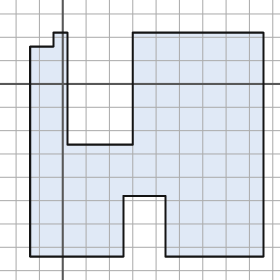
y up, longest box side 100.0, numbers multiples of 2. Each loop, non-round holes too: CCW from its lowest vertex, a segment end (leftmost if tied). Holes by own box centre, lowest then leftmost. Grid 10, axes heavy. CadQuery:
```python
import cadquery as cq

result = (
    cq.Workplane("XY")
    .moveTo(-14.0, -74.0)
    .lineTo(26.0, -74.0)
    .lineTo(26.0, -48.0)
    .lineTo(44.0, -48.0)
    .lineTo(44.0, -74.0)
    .lineTo(86.0, -74.0)
    .lineTo(86.0, 22.0)
    .lineTo(30.0, 22.0)
    .lineTo(30.0, -26.0)
    .lineTo(2.0, -26.0)
    .lineTo(2.0, 22.0)
    .lineTo(-4.0, 22.0)
    .lineTo(-4.0, 16.0)
    .lineTo(-14.0, 16.0)
    .close()
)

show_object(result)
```